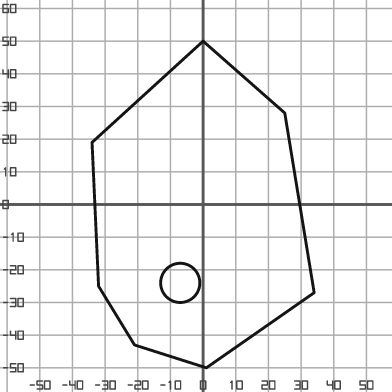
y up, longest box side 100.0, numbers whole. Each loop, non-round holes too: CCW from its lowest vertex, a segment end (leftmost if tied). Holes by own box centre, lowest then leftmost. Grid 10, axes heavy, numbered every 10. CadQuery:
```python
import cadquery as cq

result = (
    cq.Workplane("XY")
    .moveTo(1.0, -50.0)
    .lineTo(34.0, -27.0)
    .lineTo(25.0, 28.0)
    .lineTo(0.0, 50.0)
    .lineTo(-34.0, 19.0)
    .lineTo(-32.0, -25.0)
    .lineTo(-21.0, -43.0)
    .close()
    .moveTo(-7.0, -24.0)
    .circle(6.0)
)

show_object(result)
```